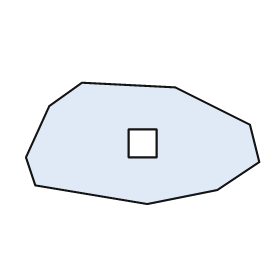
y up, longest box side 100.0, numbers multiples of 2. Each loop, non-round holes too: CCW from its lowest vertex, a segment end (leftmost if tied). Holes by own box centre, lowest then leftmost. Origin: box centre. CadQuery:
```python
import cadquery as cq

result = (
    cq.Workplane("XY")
    .moveTo(2.0, -26.0)
    .lineTo(32.0, -20.0)
    .lineTo(50.0, -8.0)
    .lineTo(46.0, 8.0)
    .lineTo(14.0, 24.0)
    .lineTo(-26.0, 26.0)
    .lineTo(-40.0, 16.0)
    .lineTo(-50.0, -6.0)
    .lineTo(-46.0, -18.0)
    .close()
    .moveTo(-6.0, -6.0)
    .lineTo(6.0, -6.0)
    .lineTo(6.0, 6.0)
    .lineTo(-6.0, 6.0)
    .close()
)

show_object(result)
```